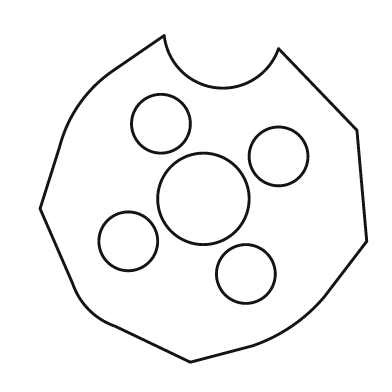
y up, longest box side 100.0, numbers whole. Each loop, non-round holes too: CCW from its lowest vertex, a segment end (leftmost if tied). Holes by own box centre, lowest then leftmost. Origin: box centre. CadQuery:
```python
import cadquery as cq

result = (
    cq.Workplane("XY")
    .moveTo(-4.0, -50.0)
    .lineTo(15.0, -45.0)
    .threePointArc((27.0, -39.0), (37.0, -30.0))
    .lineTo(50.0, -13.0)
    .lineTo(47.0, 21.0)
    .lineTo(23.0, 46.0)
    .threePointArc((4.0, 34.0), (-12.0, 50.0))
    .lineTo(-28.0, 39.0)
    .threePointArc((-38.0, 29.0), (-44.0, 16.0))
    .lineTo(-50.0, -3.0)
    .lineTo(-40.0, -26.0)
    .threePointArc((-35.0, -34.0), (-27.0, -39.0))
    .close()
    .moveTo(13.0, -23.0)
    .circle(9.0)
    .moveTo(-23.0, -13.0)
    .circle(9.0)
    .moveTo(0.0, 0.0)
    .circle(14.0)
    .moveTo(23.0, 13.0)
    .circle(9.0)
    .moveTo(-13.0, 23.0)
    .circle(9.0)
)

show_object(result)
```